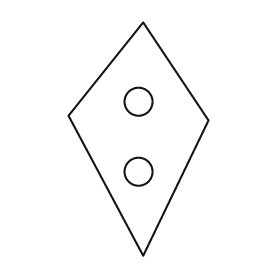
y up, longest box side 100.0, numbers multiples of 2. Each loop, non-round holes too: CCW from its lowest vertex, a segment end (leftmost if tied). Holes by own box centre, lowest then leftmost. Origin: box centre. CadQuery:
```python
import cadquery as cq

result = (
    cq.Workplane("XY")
    .moveTo(2.0, -50.0)
    .lineTo(30.0, 8.0)
    .lineTo(2.0, 50.0)
    .lineTo(-30.0, 10.0)
    .close()
    .moveTo(0.0, -14.0)
    .circle(6.0)
    .moveTo(0.0, 16.0)
    .circle(6.0)
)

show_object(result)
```